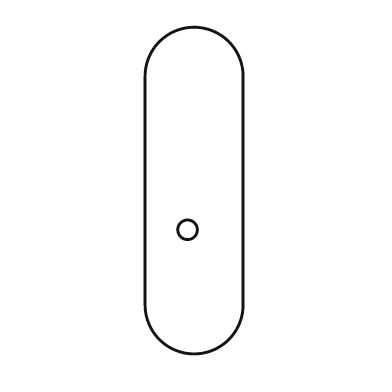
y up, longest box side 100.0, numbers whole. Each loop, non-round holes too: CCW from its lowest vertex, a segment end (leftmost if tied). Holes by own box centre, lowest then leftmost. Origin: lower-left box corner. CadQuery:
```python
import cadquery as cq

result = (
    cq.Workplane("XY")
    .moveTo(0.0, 15.0)
    .threePointArc((15.0, 0.0), (30.0, 15.0))
    .lineTo(30.0, 85.0)
    .threePointArc((15.0, 100.0), (0.0, 85.0))
    .close()
    .moveTo(13.0, 38.0)
    .circle(3.0)
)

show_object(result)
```